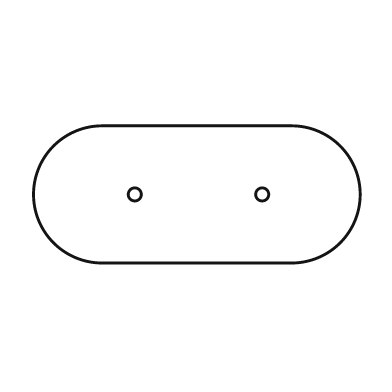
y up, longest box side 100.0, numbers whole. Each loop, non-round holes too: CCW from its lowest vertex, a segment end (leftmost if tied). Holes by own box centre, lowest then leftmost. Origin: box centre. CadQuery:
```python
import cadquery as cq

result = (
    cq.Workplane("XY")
    .moveTo(-29.0, -21.0)
    .lineTo(29.0, -21.0)
    .threePointArc((50.0, 0.0), (29.0, 21.0))
    .lineTo(-29.0, 21.0)
    .threePointArc((-50.0, 0.0), (-29.0, -21.0))
    .close()
    .moveTo(-19.0, 0.0)
    .circle(2.0)
    .moveTo(20.0, 0.0)
    .circle(2.0)
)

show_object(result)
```